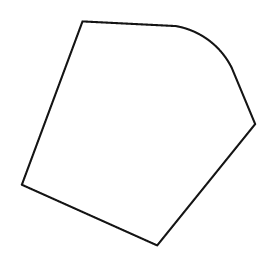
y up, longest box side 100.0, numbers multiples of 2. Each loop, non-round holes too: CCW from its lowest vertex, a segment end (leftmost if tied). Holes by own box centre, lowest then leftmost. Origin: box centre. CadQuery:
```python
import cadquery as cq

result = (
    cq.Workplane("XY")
    .moveTo(8.0, -48.0)
    .lineTo(50.0, 4.0)
    .lineTo(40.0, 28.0)
    .threePointArc((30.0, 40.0), (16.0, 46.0))
    .lineTo(-24.0, 48.0)
    .lineTo(-50.0, -22.0)
    .close()
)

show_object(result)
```